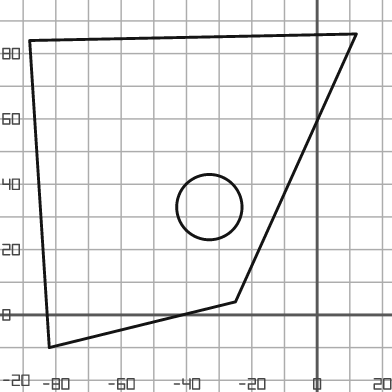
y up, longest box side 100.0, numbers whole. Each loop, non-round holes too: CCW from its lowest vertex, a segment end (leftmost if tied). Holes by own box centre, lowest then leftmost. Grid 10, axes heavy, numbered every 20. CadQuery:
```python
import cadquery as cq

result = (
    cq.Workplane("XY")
    .moveTo(-82.0, -10.0)
    .lineTo(-25.0, 4.0)
    .lineTo(12.0, 86.0)
    .lineTo(-88.0, 84.0)
    .close()
    .moveTo(-33.0, 33.0)
    .circle(10.0)
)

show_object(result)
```